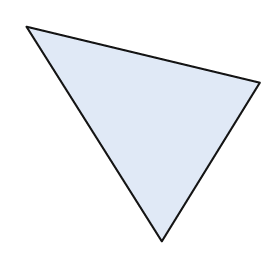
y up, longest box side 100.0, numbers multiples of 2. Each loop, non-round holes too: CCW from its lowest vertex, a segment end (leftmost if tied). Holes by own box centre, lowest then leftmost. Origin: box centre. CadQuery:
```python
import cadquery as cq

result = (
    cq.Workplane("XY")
    .moveTo(8.0, -46.0)
    .lineTo(50.0, 22.0)
    .lineTo(-50.0, 46.0)
    .close()
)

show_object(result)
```